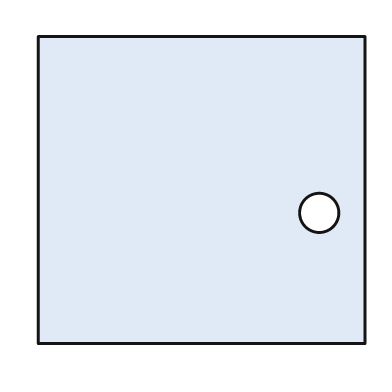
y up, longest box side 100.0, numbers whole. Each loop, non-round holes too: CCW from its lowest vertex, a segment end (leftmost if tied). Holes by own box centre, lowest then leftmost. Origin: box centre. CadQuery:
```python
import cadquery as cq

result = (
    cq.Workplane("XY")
    .moveTo(-50.0, -47.0)
    .lineTo(50.0, -47.0)
    .lineTo(50.0, 47.0)
    .lineTo(-50.0, 47.0)
    .close()
    .moveTo(36.0, -7.0)
    .circle(6.0)
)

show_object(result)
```